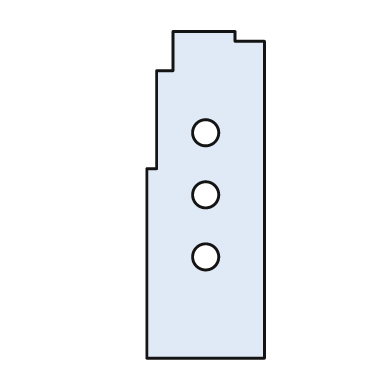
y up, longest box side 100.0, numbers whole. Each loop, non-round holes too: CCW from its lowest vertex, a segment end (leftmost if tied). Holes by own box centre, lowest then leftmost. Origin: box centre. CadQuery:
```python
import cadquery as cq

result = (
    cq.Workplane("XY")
    .moveTo(-18.0, -50.0)
    .lineTo(18.0, -50.0)
    .lineTo(18.0, 47.0)
    .lineTo(9.0, 47.0)
    .lineTo(9.0, 50.0)
    .lineTo(-10.0, 50.0)
    .lineTo(-10.0, 38.0)
    .lineTo(-15.0, 38.0)
    .lineTo(-15.0, 8.0)
    .lineTo(-18.0, 8.0)
    .close()
    .moveTo(0.0, -19.0)
    .circle(4.0)
    .moveTo(0.0, 0.0)
    .circle(4.0)
    .moveTo(0.0, 19.0)
    .circle(4.0)
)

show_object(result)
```